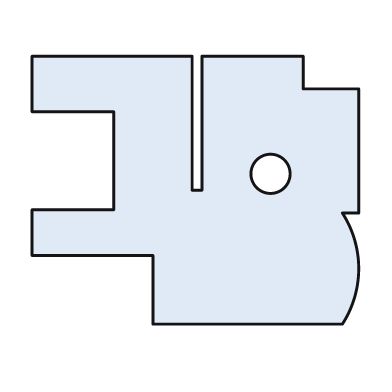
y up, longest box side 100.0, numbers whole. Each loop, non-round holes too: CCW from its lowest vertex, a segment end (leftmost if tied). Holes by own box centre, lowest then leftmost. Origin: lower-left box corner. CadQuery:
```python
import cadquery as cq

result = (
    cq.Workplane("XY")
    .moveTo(37.0, 0.0)
    .lineTo(95.0, 0.0)
    .threePointArc((100.0, 17.0), (95.0, 34.0))
    .lineTo(100.0, 34.0)
    .lineTo(100.0, 72.0)
    .lineTo(83.0, 72.0)
    .lineTo(83.0, 82.0)
    .lineTo(52.0, 82.0)
    .lineTo(52.0, 41.0)
    .lineTo(49.0, 41.0)
    .lineTo(49.0, 82.0)
    .lineTo(0.0, 82.0)
    .lineTo(0.0, 65.0)
    .lineTo(25.0, 65.0)
    .lineTo(25.0, 35.0)
    .lineTo(0.0, 35.0)
    .lineTo(0.0, 21.0)
    .lineTo(37.0, 21.0)
    .close()
    .moveTo(73.0, 46.0)
    .circle(6.0)
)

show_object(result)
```